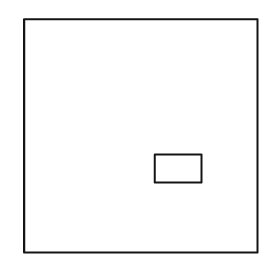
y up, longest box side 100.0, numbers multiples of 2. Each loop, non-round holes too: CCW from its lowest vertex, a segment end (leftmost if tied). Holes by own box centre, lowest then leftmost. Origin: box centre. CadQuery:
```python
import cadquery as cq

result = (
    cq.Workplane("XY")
    .moveTo(-50.0, -50.0)
    .lineTo(50.0, -50.0)
    .lineTo(50.0, 50.0)
    .lineTo(-50.0, 50.0)
    .close()
    .moveTo(6.0, -20.0)
    .lineTo(26.0, -20.0)
    .lineTo(26.0, -8.0)
    .lineTo(6.0, -8.0)
    .close()
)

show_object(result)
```